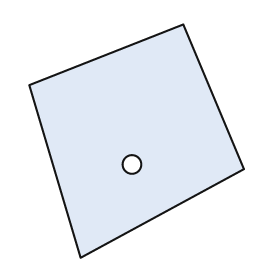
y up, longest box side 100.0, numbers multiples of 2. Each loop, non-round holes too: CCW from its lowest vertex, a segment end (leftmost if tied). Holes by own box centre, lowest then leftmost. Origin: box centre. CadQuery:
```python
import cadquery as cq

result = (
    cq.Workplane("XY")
    .moveTo(-24.0, -50.0)
    .lineTo(46.0, -12.0)
    .lineTo(20.0, 50.0)
    .lineTo(-46.0, 24.0)
    .close()
    .moveTo(-2.0, -10.0)
    .circle(4.0)
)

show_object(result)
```